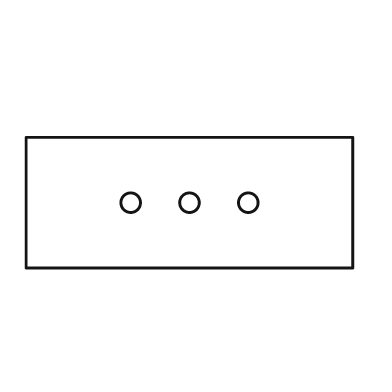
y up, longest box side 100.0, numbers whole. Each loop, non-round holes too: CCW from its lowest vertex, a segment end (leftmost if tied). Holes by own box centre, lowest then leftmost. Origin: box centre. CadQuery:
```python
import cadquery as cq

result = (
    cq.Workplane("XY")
    .moveTo(-50.0, -20.0)
    .lineTo(50.0, -20.0)
    .lineTo(50.0, 20.0)
    .lineTo(-50.0, 20.0)
    .close()
    .moveTo(-18.0, 0.0)
    .circle(3.0)
    .moveTo(0.0, 0.0)
    .circle(3.0)
    .moveTo(18.0, 0.0)
    .circle(3.0)
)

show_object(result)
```